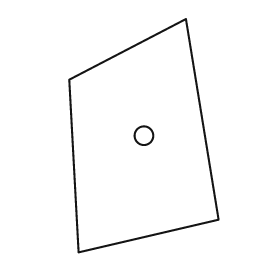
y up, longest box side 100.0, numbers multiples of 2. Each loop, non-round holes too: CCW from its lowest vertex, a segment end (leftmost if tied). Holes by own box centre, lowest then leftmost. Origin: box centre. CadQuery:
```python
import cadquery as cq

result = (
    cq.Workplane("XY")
    .moveTo(-28.0, -50.0)
    .lineTo(32.0, -36.0)
    .lineTo(18.0, 50.0)
    .lineTo(-32.0, 24.0)
    .close()
    .moveTo(0.0, 0.0)
    .circle(4.0)
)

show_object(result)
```